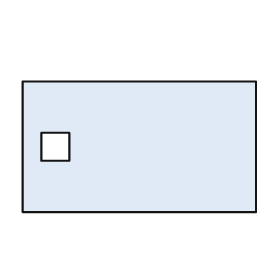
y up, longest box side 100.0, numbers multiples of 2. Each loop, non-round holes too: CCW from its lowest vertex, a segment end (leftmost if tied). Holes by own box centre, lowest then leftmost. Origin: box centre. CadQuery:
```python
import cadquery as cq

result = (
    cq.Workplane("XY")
    .moveTo(-50.0, -28.0)
    .lineTo(50.0, -28.0)
    .lineTo(50.0, 28.0)
    .lineTo(-50.0, 28.0)
    .close()
    .moveTo(-42.0, -6.0)
    .lineTo(-30.0, -6.0)
    .lineTo(-30.0, 6.0)
    .lineTo(-42.0, 6.0)
    .close()
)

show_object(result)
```